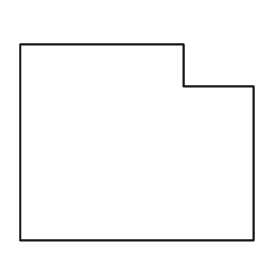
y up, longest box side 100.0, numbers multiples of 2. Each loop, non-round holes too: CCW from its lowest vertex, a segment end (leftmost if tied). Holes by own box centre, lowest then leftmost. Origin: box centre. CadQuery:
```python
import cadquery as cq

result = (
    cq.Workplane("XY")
    .moveTo(-50.0, -42.0)
    .lineTo(50.0, -42.0)
    .lineTo(50.0, 24.0)
    .lineTo(20.0, 24.0)
    .lineTo(20.0, 42.0)
    .lineTo(-50.0, 42.0)
    .close()
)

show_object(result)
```